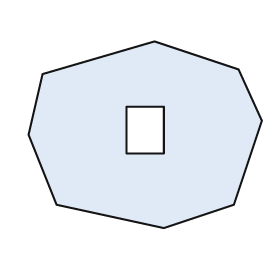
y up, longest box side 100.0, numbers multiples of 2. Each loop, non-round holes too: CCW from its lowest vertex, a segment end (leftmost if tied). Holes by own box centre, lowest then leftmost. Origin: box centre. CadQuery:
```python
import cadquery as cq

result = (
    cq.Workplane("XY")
    .moveTo(8.0, -40.0)
    .lineTo(38.0, -30.0)
    .lineTo(50.0, 6.0)
    .lineTo(40.0, 28.0)
    .lineTo(4.0, 40.0)
    .lineTo(-44.0, 26.0)
    .lineTo(-50.0, 0.0)
    .lineTo(-38.0, -30.0)
    .close()
    .moveTo(-8.0, -8.0)
    .lineTo(8.0, -8.0)
    .lineTo(8.0, 12.0)
    .lineTo(-8.0, 12.0)
    .close()
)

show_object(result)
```